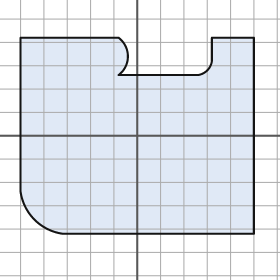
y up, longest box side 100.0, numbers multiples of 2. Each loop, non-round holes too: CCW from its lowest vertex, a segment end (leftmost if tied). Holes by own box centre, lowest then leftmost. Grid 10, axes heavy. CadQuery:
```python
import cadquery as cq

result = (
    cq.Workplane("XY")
    .moveTo(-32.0, -42.0)
    .lineTo(50.0, -42.0)
    .lineTo(50.0, 42.0)
    .lineTo(32.0, 42.0)
    .lineTo(32.0, 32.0)
    .threePointArc((30.0, 28.0), (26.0, 26.0))
    .lineTo(-8.0, 26.0)
    .threePointArc((-4.0, 34.0), (-8.0, 42.0))
    .lineTo(-50.0, 42.0)
    .lineTo(-50.0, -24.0)
    .threePointArc((-44.0, -36.0), (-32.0, -42.0))
    .close()
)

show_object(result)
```